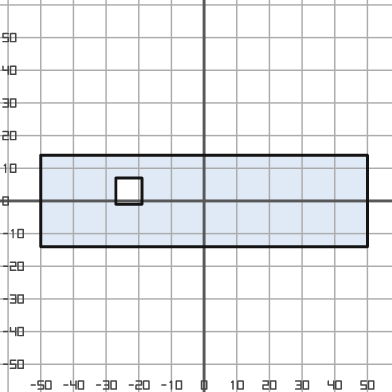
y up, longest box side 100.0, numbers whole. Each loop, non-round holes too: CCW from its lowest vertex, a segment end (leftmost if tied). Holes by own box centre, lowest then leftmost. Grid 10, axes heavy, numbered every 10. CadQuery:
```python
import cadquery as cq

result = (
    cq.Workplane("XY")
    .moveTo(-50.0, -14.0)
    .lineTo(50.0, -14.0)
    .lineTo(50.0, 14.0)
    .lineTo(-50.0, 14.0)
    .close()
    .moveTo(-27.0, -1.0)
    .lineTo(-19.0, -1.0)
    .lineTo(-19.0, 7.0)
    .lineTo(-27.0, 7.0)
    .close()
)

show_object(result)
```